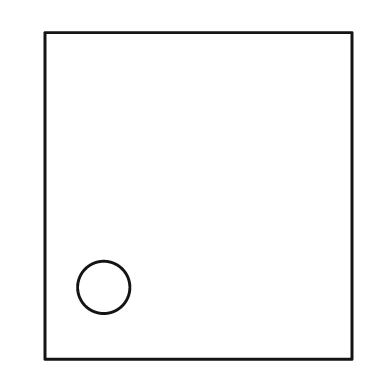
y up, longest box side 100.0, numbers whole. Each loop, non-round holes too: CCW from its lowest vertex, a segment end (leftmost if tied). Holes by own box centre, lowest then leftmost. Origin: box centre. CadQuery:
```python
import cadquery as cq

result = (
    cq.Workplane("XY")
    .moveTo(-47.0, -50.0)
    .lineTo(47.0, -50.0)
    .lineTo(47.0, 50.0)
    .lineTo(-47.0, 50.0)
    .close()
    .moveTo(-29.0, -28.0)
    .circle(8.0)
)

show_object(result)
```